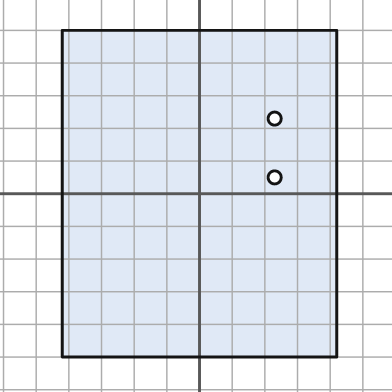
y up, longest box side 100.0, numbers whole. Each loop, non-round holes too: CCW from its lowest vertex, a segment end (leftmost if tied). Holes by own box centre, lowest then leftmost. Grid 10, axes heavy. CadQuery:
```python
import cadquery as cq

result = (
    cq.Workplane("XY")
    .moveTo(-42.0, -50.0)
    .lineTo(42.0, -50.0)
    .lineTo(42.0, 50.0)
    .lineTo(-42.0, 50.0)
    .close()
    .moveTo(23.0, 5.0)
    .circle(2.0)
    .moveTo(23.0, 23.0)
    .circle(2.0)
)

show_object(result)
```